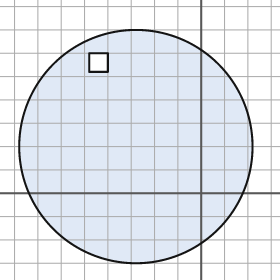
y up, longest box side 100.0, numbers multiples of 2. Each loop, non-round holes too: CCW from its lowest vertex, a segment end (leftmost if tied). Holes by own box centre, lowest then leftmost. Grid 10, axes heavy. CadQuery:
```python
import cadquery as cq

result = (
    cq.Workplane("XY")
    .moveTo(-28.0, 20.0)
    .circle(50.0)
    .moveTo(-48.0, 52.0)
    .lineTo(-40.0, 52.0)
    .lineTo(-40.0, 60.0)
    .lineTo(-48.0, 60.0)
    .close()
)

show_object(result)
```